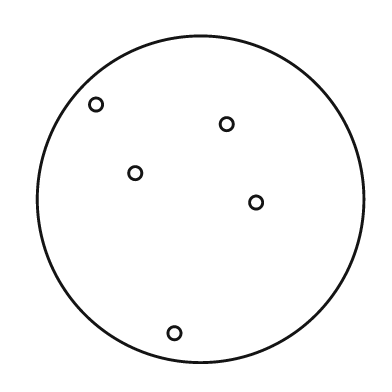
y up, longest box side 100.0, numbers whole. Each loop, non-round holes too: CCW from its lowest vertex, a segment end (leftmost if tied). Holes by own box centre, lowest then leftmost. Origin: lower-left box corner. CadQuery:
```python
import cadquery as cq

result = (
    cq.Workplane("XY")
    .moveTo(50.0, 50.0)
    .circle(50.0)
    .moveTo(42.0, 9.0)
    .circle(2.0)
    .moveTo(67.0, 49.0)
    .circle(2.0)
    .moveTo(30.0, 58.0)
    .circle(2.0)
    .moveTo(58.0, 73.0)
    .circle(2.0)
    .moveTo(18.0, 79.0)
    .circle(2.0)
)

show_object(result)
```